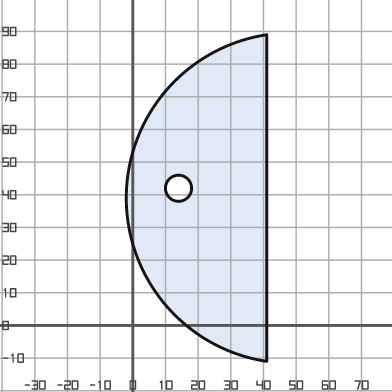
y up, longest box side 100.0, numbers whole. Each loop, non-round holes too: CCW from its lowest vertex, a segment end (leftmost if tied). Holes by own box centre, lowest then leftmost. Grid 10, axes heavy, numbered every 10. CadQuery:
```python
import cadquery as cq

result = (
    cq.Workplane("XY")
    .moveTo(41.0, -11.0)
    .lineTo(41.0, 89.0)
    .threePointArc((-2.0, 39.0), (41.0, -11.0))
    .close()
    .moveTo(14.0, 42.0)
    .circle(4.0)
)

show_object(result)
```